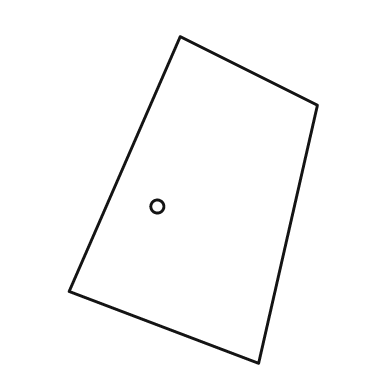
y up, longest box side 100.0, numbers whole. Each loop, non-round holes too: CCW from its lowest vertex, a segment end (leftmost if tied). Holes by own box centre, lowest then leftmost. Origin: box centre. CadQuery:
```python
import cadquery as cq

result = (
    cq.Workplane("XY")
    .moveTo(20.0, -50.0)
    .lineTo(38.0, 29.0)
    .lineTo(-4.0, 50.0)
    .lineTo(-38.0, -28.0)
    .close()
    .moveTo(-11.0, -2.0)
    .circle(2.0)
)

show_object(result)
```